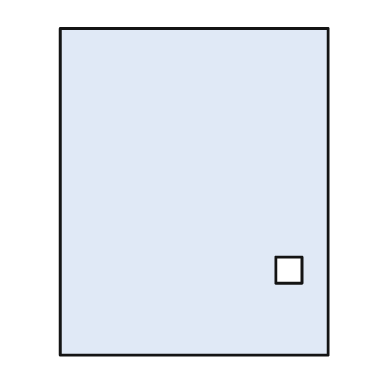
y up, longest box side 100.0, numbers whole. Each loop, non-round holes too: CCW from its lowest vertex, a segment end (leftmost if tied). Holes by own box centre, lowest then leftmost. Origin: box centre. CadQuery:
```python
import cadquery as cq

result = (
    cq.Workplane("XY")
    .moveTo(-41.0, -50.0)
    .lineTo(41.0, -50.0)
    .lineTo(41.0, 50.0)
    .lineTo(-41.0, 50.0)
    .close()
    .moveTo(25.0, -28.0)
    .lineTo(33.0, -28.0)
    .lineTo(33.0, -20.0)
    .lineTo(25.0, -20.0)
    .close()
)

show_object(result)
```